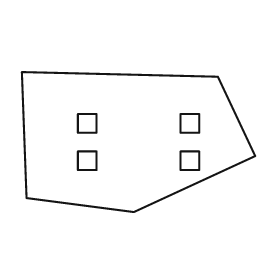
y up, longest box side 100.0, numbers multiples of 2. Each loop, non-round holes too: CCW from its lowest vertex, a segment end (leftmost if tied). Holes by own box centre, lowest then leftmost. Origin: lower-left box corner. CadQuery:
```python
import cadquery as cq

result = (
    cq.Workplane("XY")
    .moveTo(48.0, 0.0)
    .lineTo(100.0, 24.0)
    .lineTo(84.0, 58.0)
    .lineTo(0.0, 60.0)
    .lineTo(2.0, 6.0)
    .close()
    .moveTo(24.0, 18.0)
    .lineTo(32.0, 18.0)
    .lineTo(32.0, 26.0)
    .lineTo(24.0, 26.0)
    .close()
    .moveTo(68.0, 18.0)
    .lineTo(76.0, 18.0)
    .lineTo(76.0, 26.0)
    .lineTo(68.0, 26.0)
    .close()
    .moveTo(24.0, 34.0)
    .lineTo(32.0, 34.0)
    .lineTo(32.0, 42.0)
    .lineTo(24.0, 42.0)
    .close()
    .moveTo(68.0, 34.0)
    .lineTo(76.0, 34.0)
    .lineTo(76.0, 42.0)
    .lineTo(68.0, 42.0)
    .close()
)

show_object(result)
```